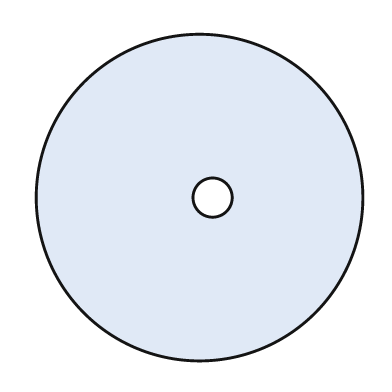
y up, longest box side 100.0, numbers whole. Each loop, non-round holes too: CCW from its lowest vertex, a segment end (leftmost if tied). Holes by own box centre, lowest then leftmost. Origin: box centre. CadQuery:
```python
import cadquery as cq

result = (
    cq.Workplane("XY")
    .moveTo(0.0, 0.0)
    .circle(50.0)
    .moveTo(4.0, 0.0)
    .circle(6.0)
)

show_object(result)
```